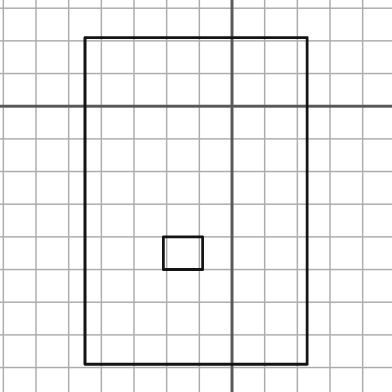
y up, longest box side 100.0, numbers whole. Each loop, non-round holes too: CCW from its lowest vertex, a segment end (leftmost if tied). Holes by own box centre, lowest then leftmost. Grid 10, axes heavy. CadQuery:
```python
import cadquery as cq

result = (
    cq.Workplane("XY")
    .moveTo(-45.0, -79.0)
    .lineTo(23.0, -79.0)
    .lineTo(23.0, 21.0)
    .lineTo(-45.0, 21.0)
    .close()
    .moveTo(-21.0, -50.0)
    .lineTo(-9.0, -50.0)
    .lineTo(-9.0, -40.0)
    .lineTo(-21.0, -40.0)
    .close()
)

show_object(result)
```